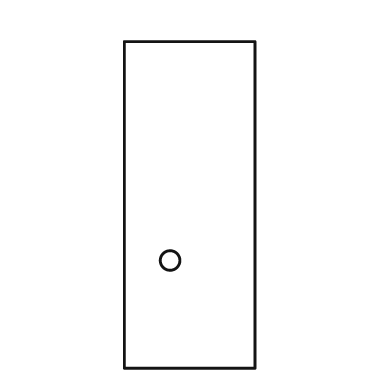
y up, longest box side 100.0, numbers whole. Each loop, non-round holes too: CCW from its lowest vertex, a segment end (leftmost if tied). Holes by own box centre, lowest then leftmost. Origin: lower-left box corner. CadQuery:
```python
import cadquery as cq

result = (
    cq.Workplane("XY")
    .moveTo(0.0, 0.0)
    .lineTo(40.0, 0.0)
    .lineTo(40.0, 100.0)
    .lineTo(0.0, 100.0)
    .close()
    .moveTo(14.0, 33.0)
    .circle(3.0)
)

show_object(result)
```